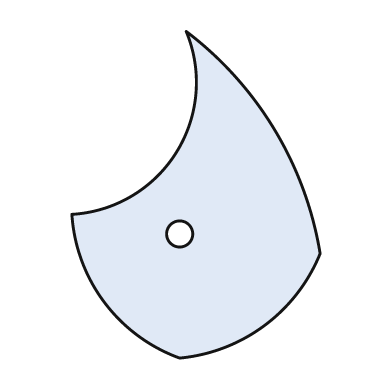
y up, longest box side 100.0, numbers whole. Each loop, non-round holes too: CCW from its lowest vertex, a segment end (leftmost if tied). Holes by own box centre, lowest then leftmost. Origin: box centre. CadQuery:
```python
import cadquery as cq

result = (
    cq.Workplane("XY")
    .moveTo(-5.0, -50.0)
    .threePointArc((21.0, -40.0), (38.0, -18.0))
    .threePointArc((24.0, 20.0), (-3.0, 50.0))
    .threePointArc((-6.0, 13.0), (-38.0, -6.0))
    .threePointArc((-28.0, -33.0), (-5.0, -50.0))
    .close()
    .moveTo(-5.0, -12.0)
    .circle(4.0)
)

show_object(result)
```